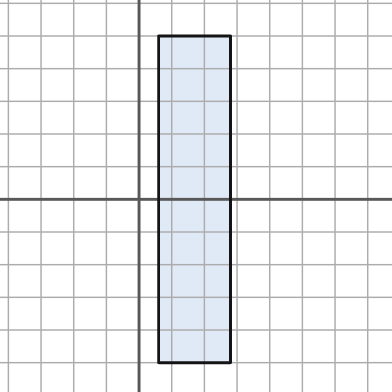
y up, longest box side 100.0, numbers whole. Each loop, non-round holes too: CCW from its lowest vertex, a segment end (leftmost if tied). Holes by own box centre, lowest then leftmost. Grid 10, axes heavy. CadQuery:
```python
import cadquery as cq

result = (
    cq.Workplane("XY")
    .moveTo(6.0, -50.0)
    .lineTo(28.0, -50.0)
    .lineTo(28.0, 50.0)
    .lineTo(6.0, 50.0)
    .close()
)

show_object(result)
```